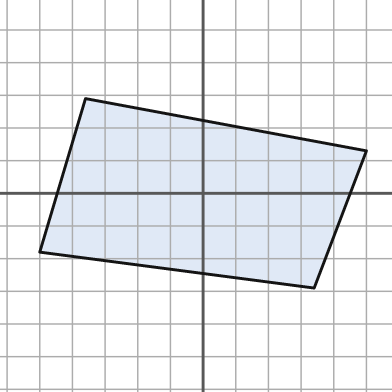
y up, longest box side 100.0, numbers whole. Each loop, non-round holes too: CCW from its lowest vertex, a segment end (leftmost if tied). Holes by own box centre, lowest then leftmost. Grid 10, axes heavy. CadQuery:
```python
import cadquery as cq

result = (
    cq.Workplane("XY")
    .moveTo(34.0, -29.0)
    .lineTo(50.0, 13.0)
    .lineTo(-36.0, 29.0)
    .lineTo(-50.0, -18.0)
    .close()
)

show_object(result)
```